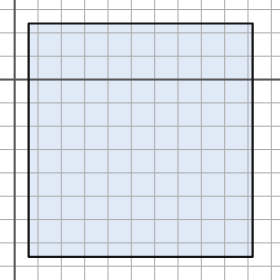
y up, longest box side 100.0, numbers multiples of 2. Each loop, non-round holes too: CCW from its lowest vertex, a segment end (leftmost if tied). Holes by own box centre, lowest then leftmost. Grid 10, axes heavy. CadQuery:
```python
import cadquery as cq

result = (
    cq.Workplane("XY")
    .moveTo(6.0, -76.0)
    .lineTo(102.0, -76.0)
    .lineTo(102.0, 24.0)
    .lineTo(6.0, 24.0)
    .close()
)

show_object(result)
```